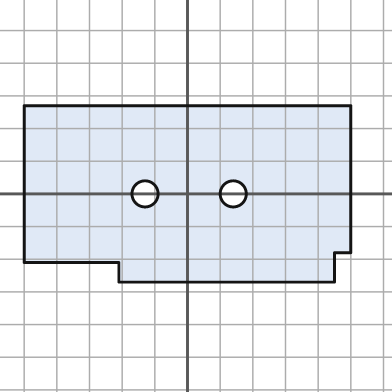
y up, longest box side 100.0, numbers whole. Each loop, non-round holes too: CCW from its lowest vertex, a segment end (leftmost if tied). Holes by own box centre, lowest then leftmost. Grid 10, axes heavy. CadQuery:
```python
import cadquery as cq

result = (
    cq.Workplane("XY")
    .moveTo(-21.0, -27.0)
    .lineTo(45.0, -27.0)
    .lineTo(45.0, -18.0)
    .lineTo(50.0, -18.0)
    .lineTo(50.0, 27.0)
    .lineTo(-50.0, 27.0)
    .lineTo(-50.0, -21.0)
    .lineTo(-21.0, -21.0)
    .close()
    .moveTo(-13.0, 0.0)
    .circle(4.0)
    .moveTo(14.0, 0.0)
    .circle(4.0)
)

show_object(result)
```